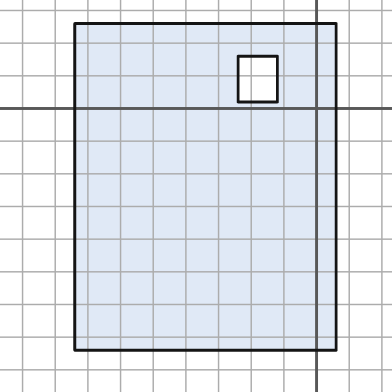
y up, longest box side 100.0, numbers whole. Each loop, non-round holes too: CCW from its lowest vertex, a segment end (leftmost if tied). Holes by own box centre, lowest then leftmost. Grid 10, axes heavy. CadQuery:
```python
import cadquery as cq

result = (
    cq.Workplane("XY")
    .moveTo(-74.0, -74.0)
    .lineTo(6.0, -74.0)
    .lineTo(6.0, 26.0)
    .lineTo(-74.0, 26.0)
    .close()
    .moveTo(-24.0, 2.0)
    .lineTo(-12.0, 2.0)
    .lineTo(-12.0, 16.0)
    .lineTo(-24.0, 16.0)
    .close()
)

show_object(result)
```